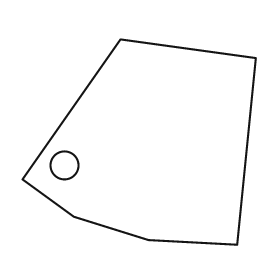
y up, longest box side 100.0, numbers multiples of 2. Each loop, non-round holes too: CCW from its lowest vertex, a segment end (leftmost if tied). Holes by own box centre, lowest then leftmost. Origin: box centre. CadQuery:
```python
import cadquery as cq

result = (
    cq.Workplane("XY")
    .moveTo(42.0, -44.0)
    .lineTo(50.0, 36.0)
    .lineTo(-8.0, 44.0)
    .lineTo(-50.0, -16.0)
    .lineTo(-28.0, -32.0)
    .lineTo(4.0, -42.0)
    .close()
    .moveTo(-32.0, -10.0)
    .circle(6.0)
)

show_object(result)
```